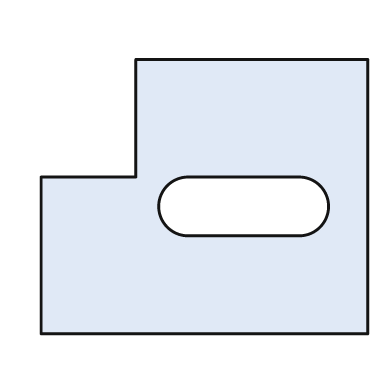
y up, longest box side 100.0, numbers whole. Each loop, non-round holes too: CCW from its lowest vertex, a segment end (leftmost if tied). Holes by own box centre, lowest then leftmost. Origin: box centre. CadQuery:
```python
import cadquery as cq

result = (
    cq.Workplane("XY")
    .moveTo(-50.0, -42.0)
    .lineTo(50.0, -42.0)
    .lineTo(50.0, 42.0)
    .lineTo(-21.0, 42.0)
    .lineTo(-21.0, 6.0)
    .lineTo(-50.0, 6.0)
    .close()
    .moveTo(-5.0, -12.0)
    .lineTo(29.0, -12.0)
    .threePointArc((38.0, -3.0), (29.0, 6.0))
    .lineTo(-5.0, 6.0)
    .threePointArc((-14.0, -3.0), (-5.0, -12.0))
    .close()
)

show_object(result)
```